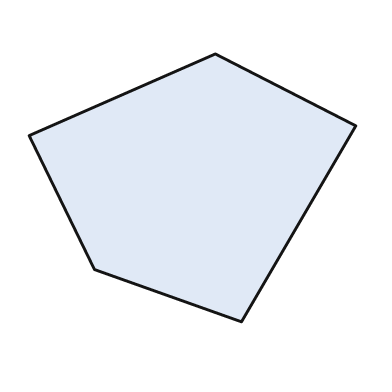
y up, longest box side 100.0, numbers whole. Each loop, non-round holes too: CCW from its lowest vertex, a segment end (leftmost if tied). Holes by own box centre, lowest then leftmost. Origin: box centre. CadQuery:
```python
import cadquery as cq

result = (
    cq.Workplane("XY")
    .moveTo(15.0, -41.0)
    .lineTo(50.0, 19.0)
    .lineTo(7.0, 41.0)
    .lineTo(-50.0, 16.0)
    .lineTo(-30.0, -25.0)
    .close()
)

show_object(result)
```